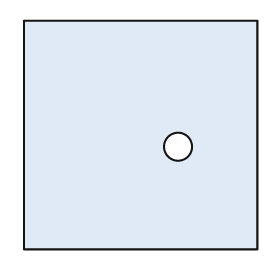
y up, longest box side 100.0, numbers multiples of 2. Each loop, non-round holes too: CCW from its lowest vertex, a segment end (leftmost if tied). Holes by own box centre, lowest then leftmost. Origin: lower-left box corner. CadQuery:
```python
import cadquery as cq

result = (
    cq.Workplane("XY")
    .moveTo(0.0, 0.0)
    .lineTo(100.0, 0.0)
    .lineTo(100.0, 98.0)
    .lineTo(0.0, 98.0)
    .close()
    .moveTo(66.0, 44.0)
    .circle(6.0)
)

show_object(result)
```